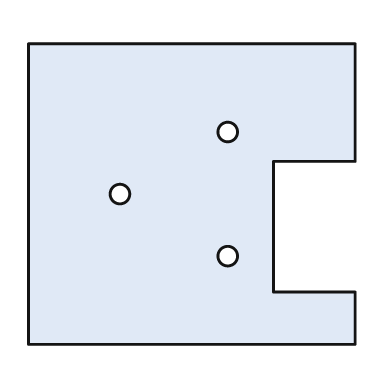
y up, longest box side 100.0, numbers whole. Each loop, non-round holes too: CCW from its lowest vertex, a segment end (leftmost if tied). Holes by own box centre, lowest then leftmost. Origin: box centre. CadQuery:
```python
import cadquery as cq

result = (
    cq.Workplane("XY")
    .moveTo(-50.0, -46.0)
    .lineTo(50.0, -46.0)
    .lineTo(50.0, -30.0)
    .lineTo(25.0, -30.0)
    .lineTo(25.0, 10.0)
    .lineTo(50.0, 10.0)
    .lineTo(50.0, 46.0)
    .lineTo(-50.0, 46.0)
    .close()
    .moveTo(11.0, -19.0)
    .circle(3.0)
    .moveTo(-22.0, 0.0)
    .circle(3.0)
    .moveTo(11.0, 19.0)
    .circle(3.0)
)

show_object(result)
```